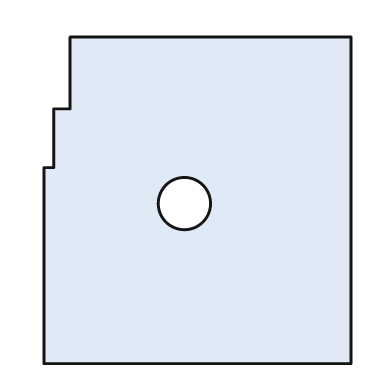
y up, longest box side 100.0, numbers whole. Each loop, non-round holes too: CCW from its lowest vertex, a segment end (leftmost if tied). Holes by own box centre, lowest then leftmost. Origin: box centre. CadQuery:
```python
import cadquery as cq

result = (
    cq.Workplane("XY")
    .moveTo(-47.0, -50.0)
    .lineTo(47.0, -50.0)
    .lineTo(47.0, 50.0)
    .lineTo(-39.0, 50.0)
    .lineTo(-39.0, 28.0)
    .lineTo(-44.0, 28.0)
    .lineTo(-44.0, 10.0)
    .lineTo(-47.0, 10.0)
    .close()
    .moveTo(-4.0, -1.0)
    .circle(8.0)
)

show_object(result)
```